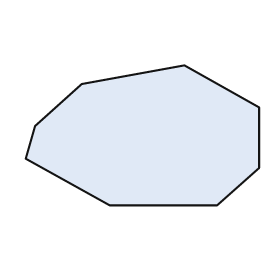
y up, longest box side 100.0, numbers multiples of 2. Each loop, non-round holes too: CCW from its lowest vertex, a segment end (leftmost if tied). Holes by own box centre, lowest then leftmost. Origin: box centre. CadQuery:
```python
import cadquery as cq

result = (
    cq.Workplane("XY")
    .moveTo(-14.0, -30.0)
    .lineTo(32.0, -30.0)
    .lineTo(50.0, -14.0)
    .lineTo(50.0, 12.0)
    .lineTo(18.0, 30.0)
    .lineTo(-26.0, 22.0)
    .lineTo(-46.0, 4.0)
    .lineTo(-50.0, -10.0)
    .close()
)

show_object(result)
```